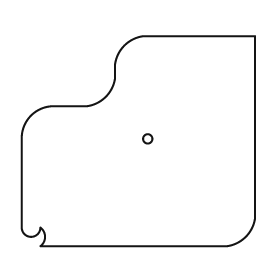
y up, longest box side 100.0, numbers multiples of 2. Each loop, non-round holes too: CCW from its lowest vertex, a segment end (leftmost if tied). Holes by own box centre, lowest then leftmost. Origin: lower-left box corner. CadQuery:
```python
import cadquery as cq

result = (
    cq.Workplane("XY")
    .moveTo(8.0, 0.0)
    .lineTo(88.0, 0.0)
    .threePointArc((96.0, 4.0), (100.0, 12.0))
    .lineTo(100.0, 90.0)
    .lineTo(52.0, 90.0)
    .threePointArc((44.0, 86.0), (40.0, 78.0))
    .lineTo(40.0, 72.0)
    .threePointArc((36.0, 64.0), (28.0, 60.0))
    .lineTo(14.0, 60.0)
    .threePointArc((4.0, 56.0), (0.0, 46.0))
    .lineTo(0.0, 8.0)
    .threePointArc((4.0, 4.0), (8.0, 8.0))
    .threePointArc((10.0, 4.0), (8.0, 0.0))
    .close()
    .moveTo(54.0, 46.0)
    .circle(2.0)
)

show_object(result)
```